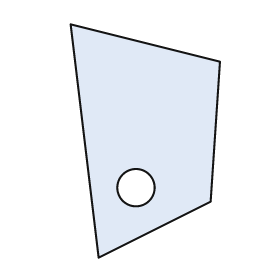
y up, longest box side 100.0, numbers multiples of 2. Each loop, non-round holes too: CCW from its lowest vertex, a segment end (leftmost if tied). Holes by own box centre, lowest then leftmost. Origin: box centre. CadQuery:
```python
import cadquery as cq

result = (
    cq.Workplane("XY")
    .moveTo(-20.0, -50.0)
    .lineTo(28.0, -26.0)
    .lineTo(32.0, 34.0)
    .lineTo(-32.0, 50.0)
    .close()
    .moveTo(-4.0, -20.0)
    .circle(8.0)
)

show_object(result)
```